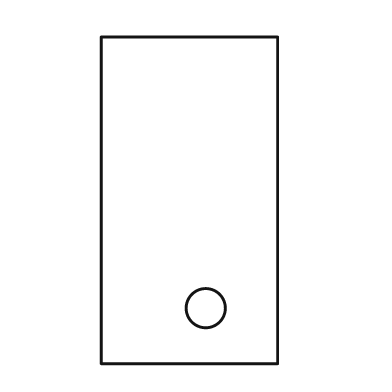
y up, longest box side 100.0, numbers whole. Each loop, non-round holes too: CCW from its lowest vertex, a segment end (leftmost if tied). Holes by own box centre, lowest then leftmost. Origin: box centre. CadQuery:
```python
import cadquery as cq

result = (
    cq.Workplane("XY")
    .moveTo(-27.0, -50.0)
    .lineTo(27.0, -50.0)
    .lineTo(27.0, 50.0)
    .lineTo(-27.0, 50.0)
    .close()
    .moveTo(5.0, -33.0)
    .circle(6.0)
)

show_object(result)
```